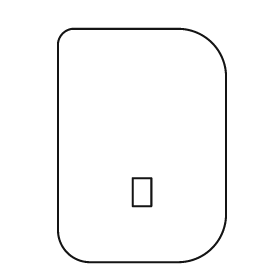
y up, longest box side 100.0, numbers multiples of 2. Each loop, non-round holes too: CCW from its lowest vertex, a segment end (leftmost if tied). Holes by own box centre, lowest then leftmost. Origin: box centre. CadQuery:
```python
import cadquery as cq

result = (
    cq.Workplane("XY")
    .moveTo(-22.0, -50.0)
    .lineTo(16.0, -50.0)
    .threePointArc((30.0, -44.0), (36.0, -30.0))
    .lineTo(36.0, 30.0)
    .threePointArc((30.0, 44.0), (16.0, 50.0))
    .lineTo(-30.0, 50.0)
    .threePointArc((-34.0, 48.0), (-36.0, 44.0))
    .lineTo(-36.0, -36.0)
    .threePointArc((-32.0, -46.0), (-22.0, -50.0))
    .close()
    .moveTo(-4.0, -26.0)
    .lineTo(4.0, -26.0)
    .lineTo(4.0, -14.0)
    .lineTo(-4.0, -14.0)
    .close()
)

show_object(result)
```